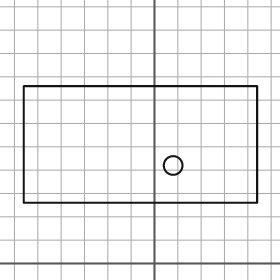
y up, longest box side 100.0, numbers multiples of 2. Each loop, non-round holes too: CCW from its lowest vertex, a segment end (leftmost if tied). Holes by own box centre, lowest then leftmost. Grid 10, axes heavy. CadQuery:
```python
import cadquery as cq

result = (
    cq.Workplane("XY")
    .moveTo(-56.0, 26.0)
    .lineTo(44.0, 26.0)
    .lineTo(44.0, 76.0)
    .lineTo(-56.0, 76.0)
    .close()
    .moveTo(8.0, 42.0)
    .circle(4.0)
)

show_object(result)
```